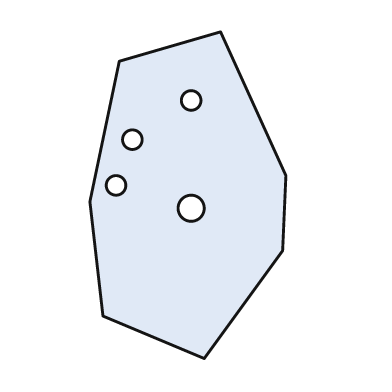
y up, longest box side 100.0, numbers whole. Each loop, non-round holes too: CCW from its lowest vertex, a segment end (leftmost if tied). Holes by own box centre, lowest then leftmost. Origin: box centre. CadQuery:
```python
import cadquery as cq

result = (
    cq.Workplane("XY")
    .moveTo(5.0, -50.0)
    .lineTo(29.0, -17.0)
    .lineTo(30.0, 6.0)
    .lineTo(10.0, 50.0)
    .lineTo(-21.0, 41.0)
    .lineTo(-30.0, -2.0)
    .lineTo(-26.0, -37.0)
    .close()
    .moveTo(1.0, -4.0)
    .circle(4.0)
    .moveTo(-22.0, 3.0)
    .circle(3.0)
    .moveTo(-17.0, 17.0)
    .circle(3.0)
    .moveTo(1.0, 29.0)
    .circle(3.0)
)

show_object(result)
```